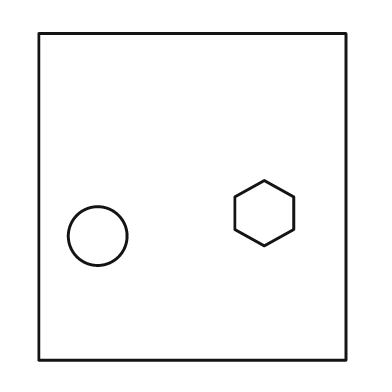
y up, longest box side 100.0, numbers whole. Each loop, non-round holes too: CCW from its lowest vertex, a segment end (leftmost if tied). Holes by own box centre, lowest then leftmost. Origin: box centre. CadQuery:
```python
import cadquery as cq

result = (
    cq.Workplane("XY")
    .moveTo(-47.0, -50.0)
    .lineTo(47.0, -50.0)
    .lineTo(47.0, 50.0)
    .lineTo(-47.0, 50.0)
    .close()
    .moveTo(-29.0, -12.0)
    .circle(9.0)
    .moveTo(22.0, -15.0)
    .lineTo(31.0, -10.0)
    .lineTo(31.0, 0.0)
    .lineTo(22.0, 5.0)
    .lineTo(13.0, 0.0)
    .lineTo(13.0, -10.0)
    .close()
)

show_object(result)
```